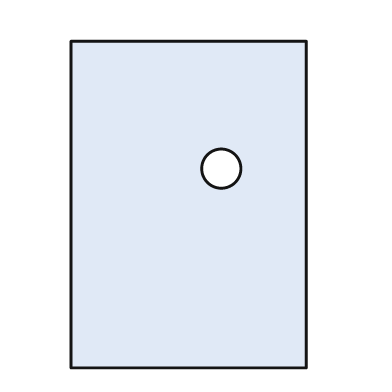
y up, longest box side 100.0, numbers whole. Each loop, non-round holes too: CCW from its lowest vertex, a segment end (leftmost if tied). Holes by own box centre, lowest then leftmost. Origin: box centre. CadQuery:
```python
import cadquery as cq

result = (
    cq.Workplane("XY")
    .moveTo(-36.0, -50.0)
    .lineTo(36.0, -50.0)
    .lineTo(36.0, 50.0)
    .lineTo(-36.0, 50.0)
    .close()
    .moveTo(10.0, 11.0)
    .circle(6.0)
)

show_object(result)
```